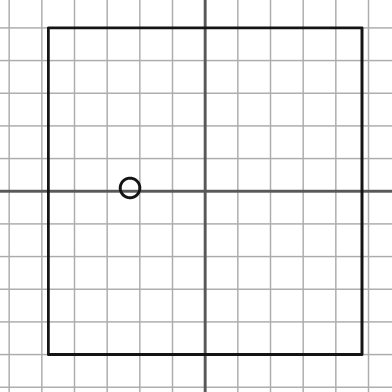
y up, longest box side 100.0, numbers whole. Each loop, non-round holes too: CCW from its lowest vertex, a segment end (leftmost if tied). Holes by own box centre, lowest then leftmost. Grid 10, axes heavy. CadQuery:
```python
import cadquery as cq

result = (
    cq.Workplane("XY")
    .moveTo(-48.0, -50.0)
    .lineTo(48.0, -50.0)
    .lineTo(48.0, 50.0)
    .lineTo(-48.0, 50.0)
    .close()
    .moveTo(-23.0, 1.0)
    .circle(3.0)
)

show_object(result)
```